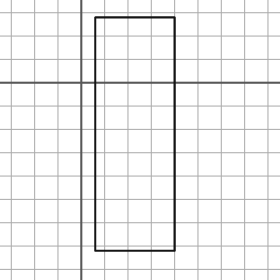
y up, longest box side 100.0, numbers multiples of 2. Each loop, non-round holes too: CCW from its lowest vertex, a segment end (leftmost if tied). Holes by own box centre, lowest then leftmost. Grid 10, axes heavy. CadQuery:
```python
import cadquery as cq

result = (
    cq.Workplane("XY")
    .moveTo(6.0, -72.0)
    .lineTo(40.0, -72.0)
    .lineTo(40.0, 28.0)
    .lineTo(6.0, 28.0)
    .close()
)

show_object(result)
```